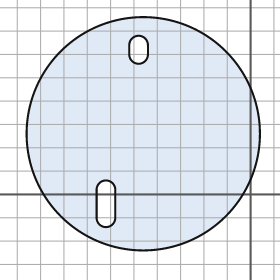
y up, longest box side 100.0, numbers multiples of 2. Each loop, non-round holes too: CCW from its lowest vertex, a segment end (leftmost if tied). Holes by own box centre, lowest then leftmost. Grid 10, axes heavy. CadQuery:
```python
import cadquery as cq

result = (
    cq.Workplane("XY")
    .moveTo(-46.0, 26.0)
    .circle(50.0)
    .moveTo(-66.0, -10.0)
    .threePointArc((-62.0, -14.0), (-58.0, -10.0))
    .lineTo(-58.0, 2.0)
    .threePointArc((-62.0, 6.0), (-66.0, 2.0))
    .close()
    .moveTo(-52.0, 60.0)
    .threePointArc((-48.0, 56.0), (-44.0, 60.0))
    .lineTo(-44.0, 64.0)
    .threePointArc((-48.0, 68.0), (-52.0, 64.0))
    .close()
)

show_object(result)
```